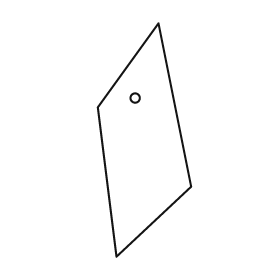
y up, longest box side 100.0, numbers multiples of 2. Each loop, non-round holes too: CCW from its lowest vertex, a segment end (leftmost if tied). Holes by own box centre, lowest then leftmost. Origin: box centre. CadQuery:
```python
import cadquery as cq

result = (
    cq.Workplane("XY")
    .moveTo(-12.0, -50.0)
    .lineTo(20.0, -20.0)
    .lineTo(6.0, 50.0)
    .lineTo(-20.0, 14.0)
    .close()
    .moveTo(-4.0, 18.0)
    .circle(2.0)
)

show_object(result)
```